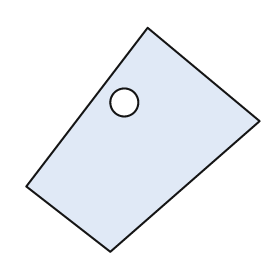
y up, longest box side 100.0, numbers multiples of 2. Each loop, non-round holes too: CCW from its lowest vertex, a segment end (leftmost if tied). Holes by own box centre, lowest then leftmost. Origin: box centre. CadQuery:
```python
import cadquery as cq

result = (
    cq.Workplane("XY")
    .moveTo(-14.0, -48.0)
    .lineTo(50.0, 8.0)
    .lineTo(2.0, 48.0)
    .lineTo(-50.0, -20.0)
    .close()
    .moveTo(-8.0, 16.0)
    .circle(6.0)
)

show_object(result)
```